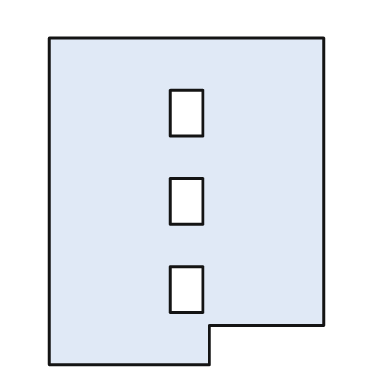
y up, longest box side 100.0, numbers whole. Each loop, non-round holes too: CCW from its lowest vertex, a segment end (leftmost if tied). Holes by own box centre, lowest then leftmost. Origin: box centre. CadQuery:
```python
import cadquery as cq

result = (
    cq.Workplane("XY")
    .moveTo(-42.0, -50.0)
    .lineTo(7.0, -50.0)
    .lineTo(7.0, -38.0)
    .lineTo(42.0, -38.0)
    .lineTo(42.0, 50.0)
    .lineTo(-42.0, 50.0)
    .close()
    .moveTo(-5.0, -34.0)
    .lineTo(5.0, -34.0)
    .lineTo(5.0, -20.0)
    .lineTo(-5.0, -20.0)
    .close()
    .moveTo(-5.0, -7.0)
    .lineTo(5.0, -7.0)
    .lineTo(5.0, 7.0)
    .lineTo(-5.0, 7.0)
    .close()
    .moveTo(-5.0, 20.0)
    .lineTo(5.0, 20.0)
    .lineTo(5.0, 34.0)
    .lineTo(-5.0, 34.0)
    .close()
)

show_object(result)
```